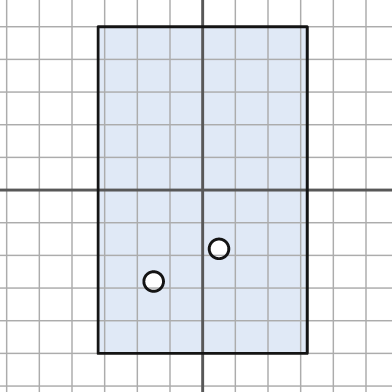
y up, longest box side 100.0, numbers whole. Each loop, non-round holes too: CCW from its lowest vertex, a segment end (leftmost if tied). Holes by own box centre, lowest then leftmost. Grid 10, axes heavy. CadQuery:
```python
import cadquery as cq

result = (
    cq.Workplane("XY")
    .moveTo(-32.0, -50.0)
    .lineTo(32.0, -50.0)
    .lineTo(32.0, 50.0)
    .lineTo(-32.0, 50.0)
    .close()
    .moveTo(-15.0, -28.0)
    .circle(3.0)
    .moveTo(5.0, -18.0)
    .circle(3.0)
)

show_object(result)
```